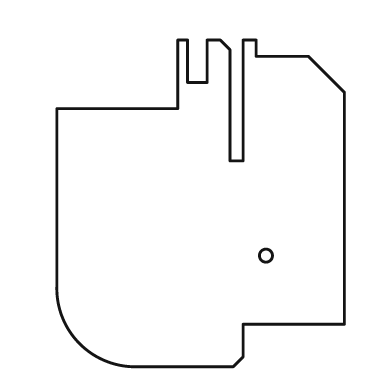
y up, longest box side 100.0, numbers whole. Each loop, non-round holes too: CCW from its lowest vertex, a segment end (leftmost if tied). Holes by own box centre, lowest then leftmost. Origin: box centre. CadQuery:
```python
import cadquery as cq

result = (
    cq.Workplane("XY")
    .moveTo(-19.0, -50.0)
    .lineTo(10.0, -50.0)
    .lineTo(13.0, -47.0)
    .lineTo(13.0, -37.0)
    .lineTo(44.0, -37.0)
    .lineTo(44.0, 34.0)
    .lineTo(33.0, 45.0)
    .lineTo(17.0, 45.0)
    .lineTo(17.0, 50.0)
    .lineTo(13.0, 50.0)
    .lineTo(13.0, 13.0)
    .lineTo(9.0, 13.0)
    .lineTo(9.0, 47.0)
    .lineTo(6.0, 50.0)
    .lineTo(2.0, 50.0)
    .lineTo(2.0, 37.0)
    .lineTo(-4.0, 37.0)
    .lineTo(-4.0, 50.0)
    .lineTo(-7.0, 50.0)
    .lineTo(-7.0, 29.0)
    .lineTo(-44.0, 29.0)
    .lineTo(-44.0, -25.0)
    .threePointArc((-37.0, -43.0), (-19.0, -50.0))
    .close()
    .moveTo(20.0, -16.0)
    .circle(2.0)
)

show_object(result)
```